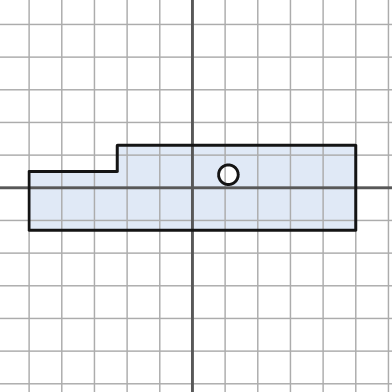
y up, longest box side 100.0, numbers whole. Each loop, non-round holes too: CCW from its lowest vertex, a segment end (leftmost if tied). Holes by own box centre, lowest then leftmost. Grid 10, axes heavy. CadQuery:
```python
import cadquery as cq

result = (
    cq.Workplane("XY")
    .moveTo(-50.0, -13.0)
    .lineTo(50.0, -13.0)
    .lineTo(50.0, 13.0)
    .lineTo(-23.0, 13.0)
    .lineTo(-23.0, 5.0)
    .lineTo(-50.0, 5.0)
    .close()
    .moveTo(11.0, 4.0)
    .circle(3.0)
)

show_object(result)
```